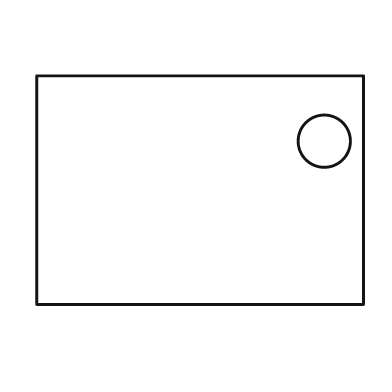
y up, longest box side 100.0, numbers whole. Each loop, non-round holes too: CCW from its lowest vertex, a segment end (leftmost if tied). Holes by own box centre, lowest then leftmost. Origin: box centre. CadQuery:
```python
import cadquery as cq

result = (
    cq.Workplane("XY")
    .moveTo(-50.0, -35.0)
    .lineTo(50.0, -35.0)
    .lineTo(50.0, 35.0)
    .lineTo(-50.0, 35.0)
    .close()
    .moveTo(38.0, 15.0)
    .circle(8.0)
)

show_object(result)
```